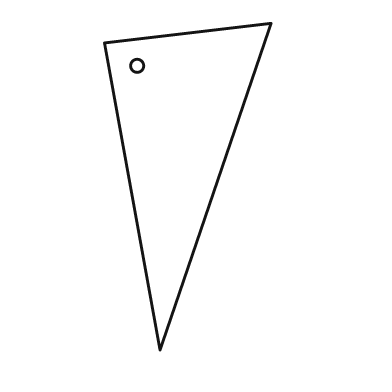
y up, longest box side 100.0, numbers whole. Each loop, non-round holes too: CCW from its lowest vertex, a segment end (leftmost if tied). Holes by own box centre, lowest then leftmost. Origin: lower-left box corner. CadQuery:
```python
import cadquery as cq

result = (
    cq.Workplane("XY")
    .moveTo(17.0, 0.0)
    .lineTo(51.0, 100.0)
    .lineTo(0.0, 94.0)
    .close()
    .moveTo(10.0, 87.0)
    .circle(2.0)
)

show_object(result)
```